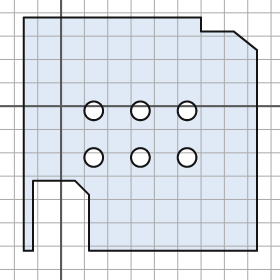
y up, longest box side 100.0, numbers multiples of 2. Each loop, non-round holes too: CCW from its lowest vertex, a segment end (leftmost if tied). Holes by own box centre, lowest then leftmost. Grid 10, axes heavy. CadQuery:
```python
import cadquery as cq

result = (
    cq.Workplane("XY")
    .moveTo(-16.0, -62.0)
    .lineTo(-12.0, -62.0)
    .lineTo(-12.0, -32.0)
    .lineTo(6.0, -32.0)
    .lineTo(12.0, -38.0)
    .lineTo(12.0, -62.0)
    .lineTo(84.0, -62.0)
    .lineTo(84.0, 24.0)
    .lineTo(74.0, 32.0)
    .lineTo(60.0, 32.0)
    .lineTo(60.0, 38.0)
    .lineTo(-16.0, 38.0)
    .close()
    .moveTo(14.0, -22.0)
    .circle(4.0)
    .moveTo(34.0, -22.0)
    .circle(4.0)
    .moveTo(54.0, -22.0)
    .circle(4.0)
    .moveTo(14.0, -2.0)
    .circle(4.0)
    .moveTo(34.0, -2.0)
    .circle(4.0)
    .moveTo(54.0, -2.0)
    .circle(4.0)
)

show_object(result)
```